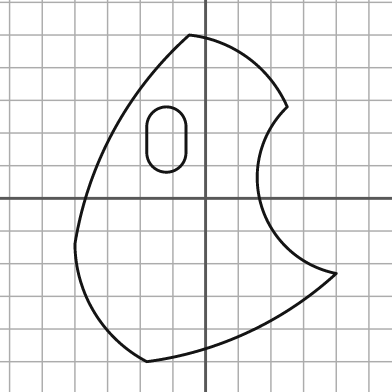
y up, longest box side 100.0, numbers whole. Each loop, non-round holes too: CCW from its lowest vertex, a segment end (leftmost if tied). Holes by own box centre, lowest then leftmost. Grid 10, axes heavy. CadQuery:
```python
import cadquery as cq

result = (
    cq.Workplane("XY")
    .moveTo(-18.0, -50.0)
    .threePointArc((13.0, -41.0), (40.0, -23.0))
    .threePointArc((17.0, -2.0), (25.0, 28.0))
    .threePointArc((13.0, 43.0), (-5.0, 50.0))
    .threePointArc((-28.0, 21.0), (-40.0, -14.0))
    .threePointArc((-34.0, -35.0), (-18.0, -50.0))
    .close()
    .moveTo(-18.0, 14.0)
    .threePointArc((-12.0, 8.0), (-6.0, 14.0))
    .lineTo(-6.0, 22.0)
    .threePointArc((-12.0, 28.0), (-18.0, 22.0))
    .close()
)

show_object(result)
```